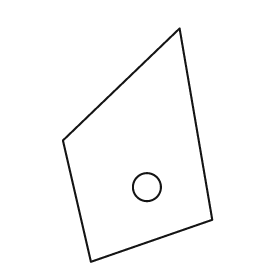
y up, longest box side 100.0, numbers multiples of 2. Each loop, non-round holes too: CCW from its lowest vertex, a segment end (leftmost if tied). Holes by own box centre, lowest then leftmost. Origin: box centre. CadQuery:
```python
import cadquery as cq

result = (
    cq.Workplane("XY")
    .moveTo(-20.0, -50.0)
    .lineTo(32.0, -32.0)
    .lineTo(18.0, 50.0)
    .lineTo(-32.0, 2.0)
    .close()
    .moveTo(4.0, -18.0)
    .circle(6.0)
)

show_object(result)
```